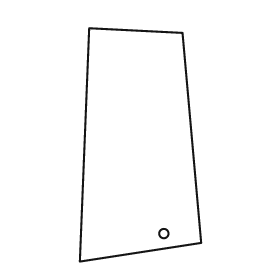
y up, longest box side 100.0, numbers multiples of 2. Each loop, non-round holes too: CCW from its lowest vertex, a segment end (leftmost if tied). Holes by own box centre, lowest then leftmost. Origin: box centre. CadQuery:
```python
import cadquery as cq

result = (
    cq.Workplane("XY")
    .moveTo(-26.0, -50.0)
    .lineTo(26.0, -42.0)
    .lineTo(18.0, 48.0)
    .lineTo(-22.0, 50.0)
    .close()
    .moveTo(10.0, -38.0)
    .circle(2.0)
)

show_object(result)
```